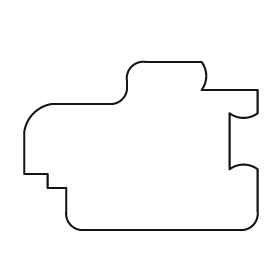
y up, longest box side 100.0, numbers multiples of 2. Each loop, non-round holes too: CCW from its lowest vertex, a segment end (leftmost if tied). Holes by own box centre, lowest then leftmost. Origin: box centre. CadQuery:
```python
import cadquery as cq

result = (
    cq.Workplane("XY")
    .moveTo(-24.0, -36.0)
    .lineTo(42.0, -36.0)
    .threePointArc((48.0, -34.0), (50.0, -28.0))
    .lineTo(50.0, -10.0)
    .threePointArc((44.0, -8.0), (38.0, -10.0))
    .lineTo(38.0, 14.0)
    .threePointArc((44.0, 12.0), (50.0, 14.0))
    .lineTo(50.0, 24.0)
    .lineTo(26.0, 24.0)
    .threePointArc((28.0, 30.0), (26.0, 36.0))
    .lineTo(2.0, 36.0)
    .threePointArc((-4.0, 34.0), (-6.0, 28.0))
    .lineTo(-6.0, 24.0)
    .threePointArc((-8.0, 20.0), (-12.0, 18.0))
    .lineTo(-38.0, 18.0)
    .threePointArc((-46.0, 14.0), (-50.0, 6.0))
    .lineTo(-50.0, -12.0)
    .lineTo(-40.0, -12.0)
    .lineTo(-40.0, -18.0)
    .lineTo(-32.0, -18.0)
    .lineTo(-32.0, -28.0)
    .threePointArc((-30.0, -34.0), (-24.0, -36.0))
    .close()
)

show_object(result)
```